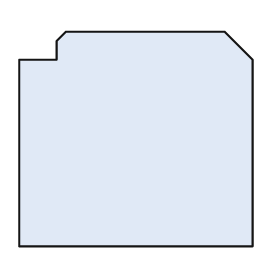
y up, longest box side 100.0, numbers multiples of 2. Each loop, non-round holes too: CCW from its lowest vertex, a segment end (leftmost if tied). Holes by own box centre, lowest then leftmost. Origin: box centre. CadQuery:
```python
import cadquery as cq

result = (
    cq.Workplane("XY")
    .moveTo(-50.0, -46.0)
    .lineTo(50.0, -46.0)
    .lineTo(50.0, 34.0)
    .lineTo(38.0, 46.0)
    .lineTo(-30.0, 46.0)
    .lineTo(-34.0, 42.0)
    .lineTo(-34.0, 34.0)
    .lineTo(-50.0, 34.0)
    .close()
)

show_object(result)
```